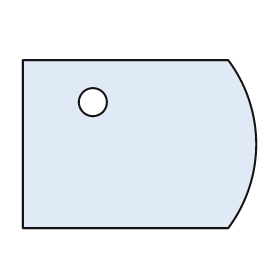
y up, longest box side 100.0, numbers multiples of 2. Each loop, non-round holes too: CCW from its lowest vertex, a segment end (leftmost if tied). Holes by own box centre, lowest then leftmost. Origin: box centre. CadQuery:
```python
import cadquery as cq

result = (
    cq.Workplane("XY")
    .moveTo(-50.0, -36.0)
    .lineTo(38.0, -36.0)
    .threePointArc((50.0, 0.0), (38.0, 36.0))
    .lineTo(-50.0, 36.0)
    .close()
    .moveTo(-20.0, 18.0)
    .circle(6.0)
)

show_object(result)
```